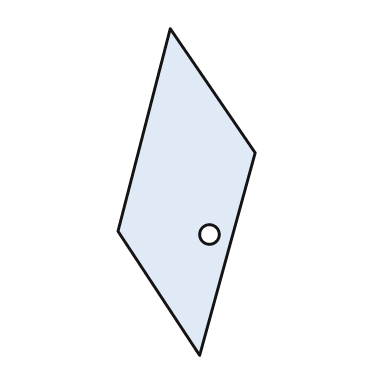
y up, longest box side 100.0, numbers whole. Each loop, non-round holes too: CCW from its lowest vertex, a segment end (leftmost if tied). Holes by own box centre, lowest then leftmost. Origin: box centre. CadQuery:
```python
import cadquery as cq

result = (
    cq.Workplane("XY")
    .moveTo(4.0, -50.0)
    .lineTo(21.0, 12.0)
    .lineTo(-5.0, 50.0)
    .lineTo(-21.0, -12.0)
    .close()
    .moveTo(7.0, -13.0)
    .circle(3.0)
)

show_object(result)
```